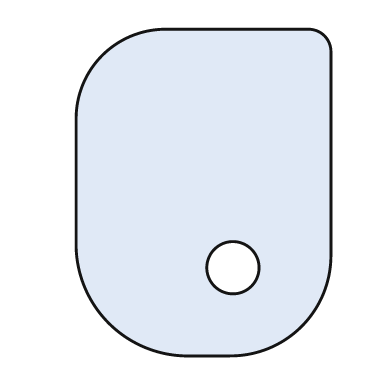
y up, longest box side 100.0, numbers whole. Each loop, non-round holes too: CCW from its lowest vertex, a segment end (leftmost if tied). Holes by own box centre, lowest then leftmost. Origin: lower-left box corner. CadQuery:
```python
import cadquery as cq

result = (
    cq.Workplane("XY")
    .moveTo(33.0, 0.0)
    .lineTo(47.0, 0.0)
    .threePointArc((69.0, 9.0), (78.0, 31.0))
    .lineTo(78.0, 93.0)
    .threePointArc((76.0, 98.0), (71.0, 100.0))
    .lineTo(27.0, 100.0)
    .threePointArc((8.0, 92.0), (0.0, 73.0))
    .lineTo(0.0, 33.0)
    .threePointArc((10.0, 10.0), (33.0, 0.0))
    .close()
    .moveTo(48.0, 27.0)
    .circle(8.0)
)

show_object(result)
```